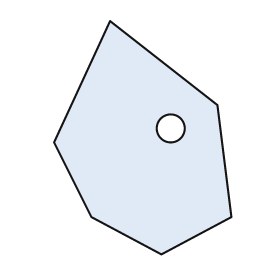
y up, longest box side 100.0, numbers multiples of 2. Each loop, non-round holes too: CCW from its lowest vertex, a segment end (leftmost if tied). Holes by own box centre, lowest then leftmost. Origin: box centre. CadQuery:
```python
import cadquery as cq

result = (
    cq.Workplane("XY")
    .moveTo(8.0, -50.0)
    .lineTo(38.0, -34.0)
    .lineTo(32.0, 14.0)
    .lineTo(-14.0, 50.0)
    .lineTo(-38.0, -2.0)
    .lineTo(-22.0, -34.0)
    .close()
    .moveTo(12.0, 4.0)
    .circle(6.0)
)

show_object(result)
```